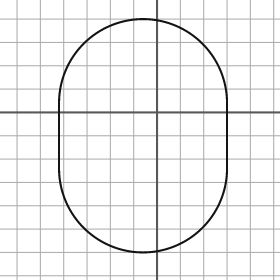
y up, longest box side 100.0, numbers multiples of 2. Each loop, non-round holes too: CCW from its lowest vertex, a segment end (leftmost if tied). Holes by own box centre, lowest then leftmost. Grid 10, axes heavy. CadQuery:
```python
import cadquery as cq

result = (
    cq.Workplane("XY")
    .moveTo(-42.0, -24.0)
    .threePointArc((-6.0, -60.0), (30.0, -24.0))
    .lineTo(30.0, 4.0)
    .threePointArc((-6.0, 40.0), (-42.0, 4.0))
    .close()
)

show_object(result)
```